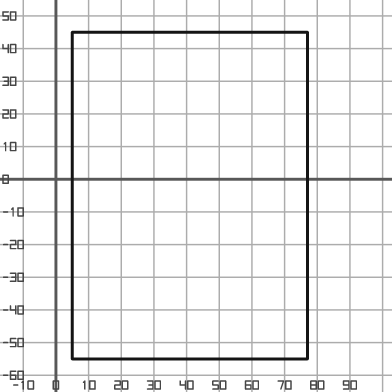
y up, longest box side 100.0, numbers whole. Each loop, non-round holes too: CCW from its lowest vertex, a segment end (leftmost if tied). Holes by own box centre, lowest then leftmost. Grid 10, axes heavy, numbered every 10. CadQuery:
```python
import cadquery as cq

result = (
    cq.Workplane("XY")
    .moveTo(5.0, -55.0)
    .lineTo(77.0, -55.0)
    .lineTo(77.0, 45.0)
    .lineTo(5.0, 45.0)
    .close()
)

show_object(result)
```